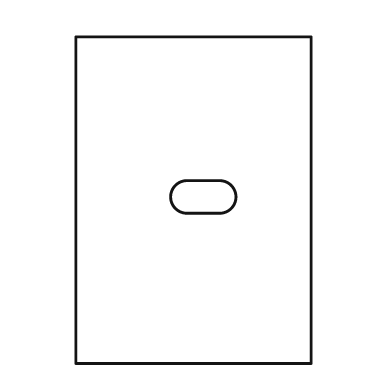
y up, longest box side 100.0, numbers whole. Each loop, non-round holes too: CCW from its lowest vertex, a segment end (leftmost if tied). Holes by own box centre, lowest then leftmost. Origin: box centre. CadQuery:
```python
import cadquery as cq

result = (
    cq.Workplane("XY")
    .moveTo(-36.0, -50.0)
    .lineTo(36.0, -50.0)
    .lineTo(36.0, 50.0)
    .lineTo(-36.0, 50.0)
    .close()
    .moveTo(-2.0, -4.0)
    .lineTo(8.0, -4.0)
    .threePointArc((13.0, 1.0), (8.0, 6.0))
    .lineTo(-2.0, 6.0)
    .threePointArc((-7.0, 1.0), (-2.0, -4.0))
    .close()
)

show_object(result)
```